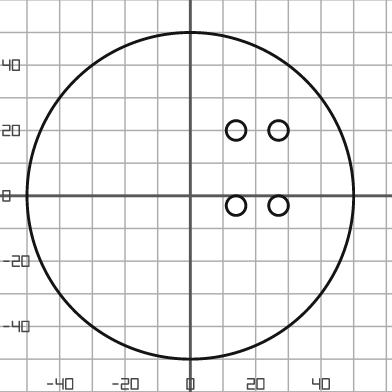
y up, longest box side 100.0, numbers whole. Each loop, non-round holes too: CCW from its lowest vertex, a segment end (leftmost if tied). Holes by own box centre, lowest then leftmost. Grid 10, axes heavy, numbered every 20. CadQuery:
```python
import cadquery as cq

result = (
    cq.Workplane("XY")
    .moveTo(0.0, 0.0)
    .circle(50.0)
    .moveTo(14.0, -3.0)
    .circle(3.0)
    .moveTo(27.0, -3.0)
    .circle(3.0)
    .moveTo(14.0, 20.0)
    .circle(3.0)
    .moveTo(27.0, 20.0)
    .circle(3.0)
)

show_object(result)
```